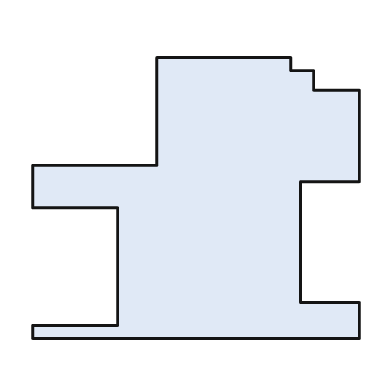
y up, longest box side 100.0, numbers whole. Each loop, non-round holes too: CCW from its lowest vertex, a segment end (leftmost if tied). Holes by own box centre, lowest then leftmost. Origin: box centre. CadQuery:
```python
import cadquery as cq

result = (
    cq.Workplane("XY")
    .moveTo(-50.0, -43.0)
    .lineTo(50.0, -43.0)
    .lineTo(50.0, -32.0)
    .lineTo(32.0, -32.0)
    .lineTo(32.0, 5.0)
    .lineTo(50.0, 5.0)
    .lineTo(50.0, 33.0)
    .lineTo(36.0, 33.0)
    .lineTo(36.0, 39.0)
    .lineTo(29.0, 39.0)
    .lineTo(29.0, 43.0)
    .lineTo(-12.0, 43.0)
    .lineTo(-12.0, 10.0)
    .lineTo(-50.0, 10.0)
    .lineTo(-50.0, -3.0)
    .lineTo(-24.0, -3.0)
    .lineTo(-24.0, -39.0)
    .lineTo(-50.0, -39.0)
    .close()
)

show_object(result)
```